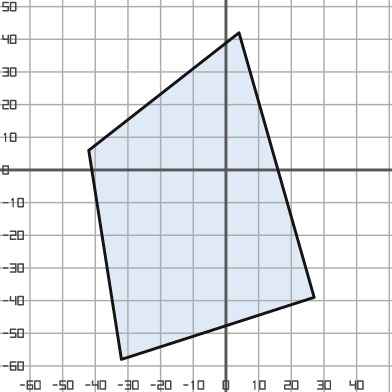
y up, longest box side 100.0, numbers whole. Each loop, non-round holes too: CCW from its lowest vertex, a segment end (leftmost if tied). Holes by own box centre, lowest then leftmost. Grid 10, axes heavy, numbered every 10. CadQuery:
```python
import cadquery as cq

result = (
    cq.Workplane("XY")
    .moveTo(-32.0, -58.0)
    .lineTo(27.0, -39.0)
    .lineTo(4.0, 42.0)
    .lineTo(-42.0, 6.0)
    .close()
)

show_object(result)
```